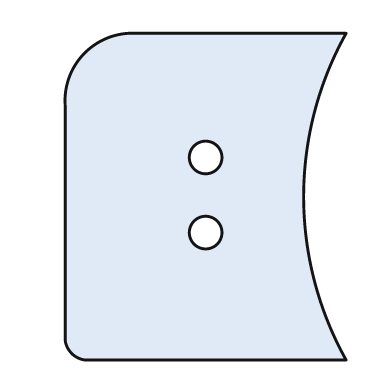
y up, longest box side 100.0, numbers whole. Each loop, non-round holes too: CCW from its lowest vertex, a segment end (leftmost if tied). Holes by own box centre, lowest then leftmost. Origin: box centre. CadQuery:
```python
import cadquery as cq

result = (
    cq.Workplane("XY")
    .moveTo(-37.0, -50.0)
    .lineTo(43.0, -50.0)
    .threePointArc((30.0, 0.0), (43.0, 50.0))
    .lineTo(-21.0, 50.0)
    .threePointArc((-37.0, 44.0), (-43.0, 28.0))
    .lineTo(-43.0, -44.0)
    .threePointArc((-41.0, -48.0), (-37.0, -50.0))
    .close()
    .moveTo(0.0, -11.0)
    .circle(5.0)
    .moveTo(0.0, 12.0)
    .circle(5.0)
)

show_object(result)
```